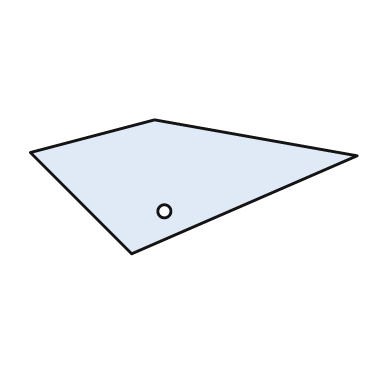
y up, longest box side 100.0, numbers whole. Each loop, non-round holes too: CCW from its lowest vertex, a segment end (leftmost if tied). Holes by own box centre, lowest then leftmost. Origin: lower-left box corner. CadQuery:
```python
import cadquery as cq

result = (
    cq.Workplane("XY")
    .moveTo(31.0, 0.0)
    .lineTo(100.0, 30.0)
    .lineTo(38.0, 41.0)
    .lineTo(0.0, 31.0)
    .close()
    .moveTo(41.0, 13.0)
    .circle(2.0)
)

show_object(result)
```